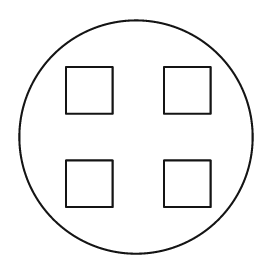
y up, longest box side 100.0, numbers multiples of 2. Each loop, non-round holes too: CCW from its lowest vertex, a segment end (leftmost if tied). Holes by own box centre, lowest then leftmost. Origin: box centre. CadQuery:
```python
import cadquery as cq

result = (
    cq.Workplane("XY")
    .moveTo(0.0, 0.0)
    .circle(50.0)
    .moveTo(-30.0, -30.0)
    .lineTo(-10.0, -30.0)
    .lineTo(-10.0, -10.0)
    .lineTo(-30.0, -10.0)
    .close()
    .moveTo(12.0, -30.0)
    .lineTo(32.0, -30.0)
    .lineTo(32.0, -10.0)
    .lineTo(12.0, -10.0)
    .close()
    .moveTo(-30.0, 10.0)
    .lineTo(-10.0, 10.0)
    .lineTo(-10.0, 30.0)
    .lineTo(-30.0, 30.0)
    .close()
    .moveTo(12.0, 10.0)
    .lineTo(32.0, 10.0)
    .lineTo(32.0, 30.0)
    .lineTo(12.0, 30.0)
    .close()
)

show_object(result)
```